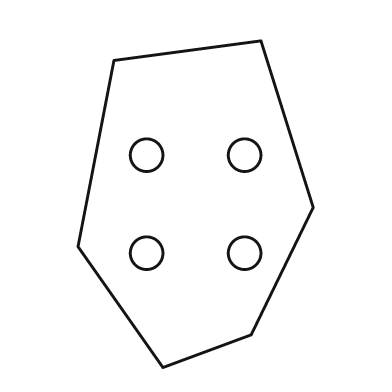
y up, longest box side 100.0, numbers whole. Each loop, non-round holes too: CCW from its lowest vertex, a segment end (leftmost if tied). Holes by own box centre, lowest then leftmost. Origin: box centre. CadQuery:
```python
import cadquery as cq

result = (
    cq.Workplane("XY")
    .moveTo(-10.0, -50.0)
    .lineTo(17.0, -40.0)
    .lineTo(36.0, -1.0)
    .lineTo(20.0, 50.0)
    .lineTo(-25.0, 44.0)
    .lineTo(-36.0, -13.0)
    .close()
    .moveTo(-15.0, -15.0)
    .circle(5.0)
    .moveTo(15.0, -15.0)
    .circle(5.0)
    .moveTo(-15.0, 15.0)
    .circle(5.0)
    .moveTo(15.0, 15.0)
    .circle(5.0)
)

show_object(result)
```